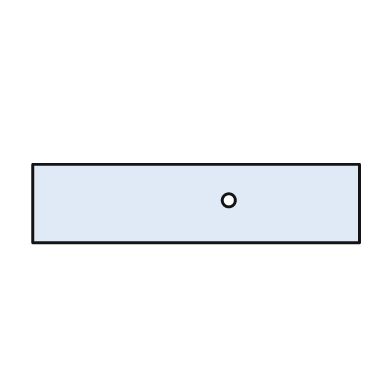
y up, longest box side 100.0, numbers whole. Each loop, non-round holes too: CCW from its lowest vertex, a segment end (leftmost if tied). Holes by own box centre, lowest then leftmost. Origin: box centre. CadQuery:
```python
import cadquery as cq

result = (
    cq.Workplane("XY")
    .moveTo(-50.0, -12.0)
    .lineTo(50.0, -12.0)
    .lineTo(50.0, 12.0)
    .lineTo(-50.0, 12.0)
    .close()
    .moveTo(10.0, 1.0)
    .circle(2.0)
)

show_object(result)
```